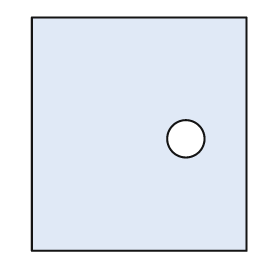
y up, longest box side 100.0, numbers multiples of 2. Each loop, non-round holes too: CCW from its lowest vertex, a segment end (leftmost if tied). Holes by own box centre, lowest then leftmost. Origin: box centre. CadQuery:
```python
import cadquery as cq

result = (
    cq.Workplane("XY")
    .moveTo(-46.0, -50.0)
    .lineTo(46.0, -50.0)
    .lineTo(46.0, 50.0)
    .lineTo(-46.0, 50.0)
    .close()
    .moveTo(20.0, -2.0)
    .circle(8.0)
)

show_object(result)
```